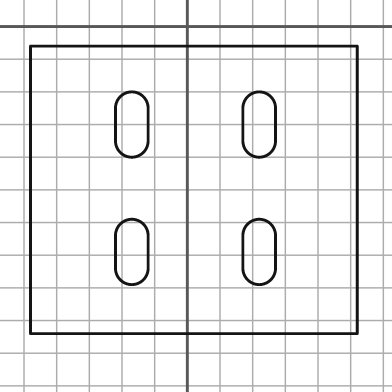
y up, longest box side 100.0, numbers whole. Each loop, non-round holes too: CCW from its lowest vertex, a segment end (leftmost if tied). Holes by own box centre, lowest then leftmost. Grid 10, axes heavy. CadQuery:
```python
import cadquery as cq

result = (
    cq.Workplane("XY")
    .moveTo(-48.0, -94.0)
    .lineTo(52.0, -94.0)
    .lineTo(52.0, -6.0)
    .lineTo(-48.0, -6.0)
    .close()
    .moveTo(-22.0, -74.0)
    .threePointArc((-17.0, -79.0), (-12.0, -74.0))
    .lineTo(-12.0, -64.0)
    .threePointArc((-17.0, -59.0), (-22.0, -64.0))
    .close()
    .moveTo(17.0, -74.0)
    .threePointArc((22.0, -79.0), (27.0, -74.0))
    .lineTo(27.0, -64.0)
    .threePointArc((22.0, -59.0), (17.0, -64.0))
    .close()
    .moveTo(-22.0, -35.0)
    .threePointArc((-17.0, -40.0), (-12.0, -35.0))
    .lineTo(-12.0, -25.0)
    .threePointArc((-17.0, -20.0), (-22.0, -25.0))
    .close()
    .moveTo(17.0, -35.0)
    .threePointArc((22.0, -40.0), (27.0, -35.0))
    .lineTo(27.0, -25.0)
    .threePointArc((22.0, -20.0), (17.0, -25.0))
    .close()
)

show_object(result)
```